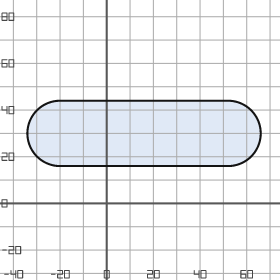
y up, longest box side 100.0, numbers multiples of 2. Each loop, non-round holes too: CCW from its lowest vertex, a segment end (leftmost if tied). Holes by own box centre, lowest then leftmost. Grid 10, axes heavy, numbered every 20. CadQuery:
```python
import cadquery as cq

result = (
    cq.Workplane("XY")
    .moveTo(-20.0, 16.0)
    .lineTo(52.0, 16.0)
    .threePointArc((66.0, 30.0), (52.0, 44.0))
    .lineTo(-20.0, 44.0)
    .threePointArc((-34.0, 30.0), (-20.0, 16.0))
    .close()
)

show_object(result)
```